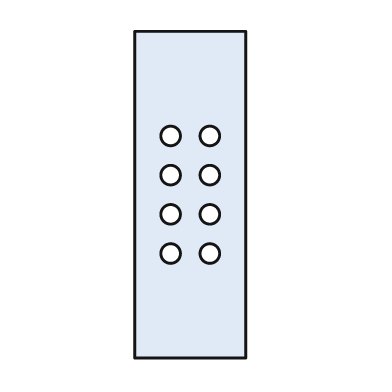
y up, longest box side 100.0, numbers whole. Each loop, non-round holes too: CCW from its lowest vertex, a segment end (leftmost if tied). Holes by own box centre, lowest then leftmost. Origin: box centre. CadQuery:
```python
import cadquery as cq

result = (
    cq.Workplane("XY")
    .moveTo(-17.0, -50.0)
    .lineTo(17.0, -50.0)
    .lineTo(17.0, 50.0)
    .lineTo(-17.0, 50.0)
    .close()
    .moveTo(-6.0, -18.0)
    .circle(3.0)
    .moveTo(6.0, -18.0)
    .circle(3.0)
    .moveTo(-6.0, -6.0)
    .circle(3.0)
    .moveTo(6.0, -6.0)
    .circle(3.0)
    .moveTo(-6.0, 6.0)
    .circle(3.0)
    .moveTo(6.0, 6.0)
    .circle(3.0)
    .moveTo(-6.0, 18.0)
    .circle(3.0)
    .moveTo(6.0, 18.0)
    .circle(3.0)
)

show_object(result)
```